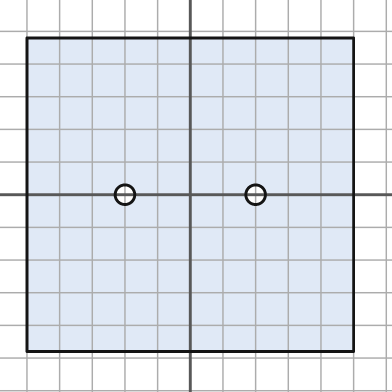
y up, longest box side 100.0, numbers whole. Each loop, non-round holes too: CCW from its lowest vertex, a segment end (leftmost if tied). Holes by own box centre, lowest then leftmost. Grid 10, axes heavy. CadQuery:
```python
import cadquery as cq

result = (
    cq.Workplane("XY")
    .moveTo(-50.0, -48.0)
    .lineTo(50.0, -48.0)
    .lineTo(50.0, 48.0)
    .lineTo(-50.0, 48.0)
    .close()
    .moveTo(-20.0, 0.0)
    .circle(3.0)
    .moveTo(20.0, 0.0)
    .circle(3.0)
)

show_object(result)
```